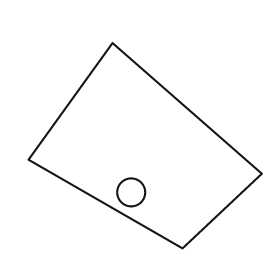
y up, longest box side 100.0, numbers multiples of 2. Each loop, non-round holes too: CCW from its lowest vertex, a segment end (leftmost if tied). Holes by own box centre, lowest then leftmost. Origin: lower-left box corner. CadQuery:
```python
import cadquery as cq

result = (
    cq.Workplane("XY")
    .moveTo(66.0, 0.0)
    .lineTo(100.0, 32.0)
    .lineTo(36.0, 88.0)
    .lineTo(0.0, 38.0)
    .close()
    .moveTo(44.0, 24.0)
    .circle(6.0)
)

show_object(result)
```